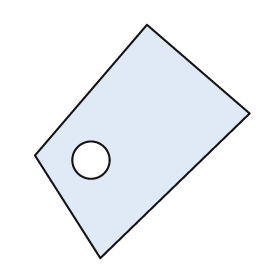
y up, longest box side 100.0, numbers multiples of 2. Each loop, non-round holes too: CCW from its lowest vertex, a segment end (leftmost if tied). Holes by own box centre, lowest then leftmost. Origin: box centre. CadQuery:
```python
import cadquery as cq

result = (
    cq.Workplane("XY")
    .moveTo(-18.0, -50.0)
    .lineTo(46.0, 12.0)
    .lineTo(2.0, 50.0)
    .lineTo(-46.0, -6.0)
    .close()
    .moveTo(-22.0, -8.0)
    .circle(8.0)
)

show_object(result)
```